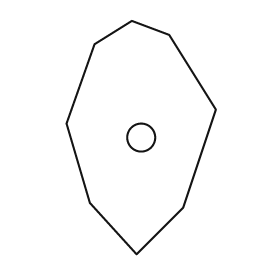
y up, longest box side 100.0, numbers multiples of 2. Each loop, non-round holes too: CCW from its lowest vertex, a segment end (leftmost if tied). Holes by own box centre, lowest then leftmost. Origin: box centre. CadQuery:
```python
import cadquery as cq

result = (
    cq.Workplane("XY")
    .moveTo(-2.0, -50.0)
    .lineTo(18.0, -30.0)
    .lineTo(32.0, 12.0)
    .lineTo(12.0, 44.0)
    .lineTo(-4.0, 50.0)
    .lineTo(-20.0, 40.0)
    .lineTo(-32.0, 6.0)
    .lineTo(-22.0, -28.0)
    .close()
    .moveTo(0.0, 0.0)
    .circle(6.0)
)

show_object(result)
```